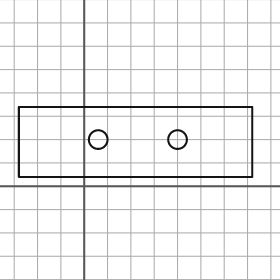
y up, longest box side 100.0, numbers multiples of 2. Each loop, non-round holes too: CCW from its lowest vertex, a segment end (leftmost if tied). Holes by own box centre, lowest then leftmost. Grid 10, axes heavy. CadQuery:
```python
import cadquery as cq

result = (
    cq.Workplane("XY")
    .moveTo(-28.0, 4.0)
    .lineTo(72.0, 4.0)
    .lineTo(72.0, 34.0)
    .lineTo(-28.0, 34.0)
    .close()
    .moveTo(6.0, 20.0)
    .circle(4.0)
    .moveTo(40.0, 20.0)
    .circle(4.0)
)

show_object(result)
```